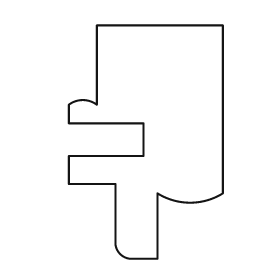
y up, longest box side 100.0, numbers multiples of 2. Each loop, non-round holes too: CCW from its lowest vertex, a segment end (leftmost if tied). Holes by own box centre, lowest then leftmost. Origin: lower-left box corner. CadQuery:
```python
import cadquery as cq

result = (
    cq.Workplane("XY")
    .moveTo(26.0, 0.0)
    .lineTo(38.0, 0.0)
    .lineTo(38.0, 28.0)
    .threePointArc((52.0, 24.0), (66.0, 28.0))
    .lineTo(66.0, 100.0)
    .lineTo(12.0, 100.0)
    .lineTo(12.0, 66.0)
    .threePointArc((6.0, 68.0), (0.0, 66.0))
    .lineTo(0.0, 58.0)
    .lineTo(32.0, 58.0)
    .lineTo(32.0, 44.0)
    .lineTo(0.0, 44.0)
    .lineTo(0.0, 32.0)
    .lineTo(20.0, 32.0)
    .lineTo(20.0, 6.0)
    .threePointArc((22.0, 2.0), (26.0, 0.0))
    .close()
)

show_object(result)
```